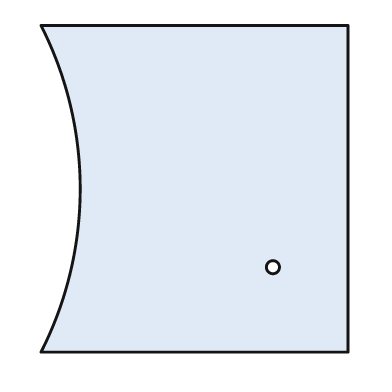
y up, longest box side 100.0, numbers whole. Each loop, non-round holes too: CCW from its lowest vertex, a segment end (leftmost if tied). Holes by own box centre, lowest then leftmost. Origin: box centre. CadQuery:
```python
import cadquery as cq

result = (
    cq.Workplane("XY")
    .moveTo(-47.0, -50.0)
    .lineTo(47.0, -50.0)
    .lineTo(47.0, 50.0)
    .lineTo(-47.0, 50.0)
    .threePointArc((-35.0, 0.0), (-47.0, -50.0))
    .close()
    .moveTo(24.0, -24.0)
    .circle(2.0)
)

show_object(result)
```